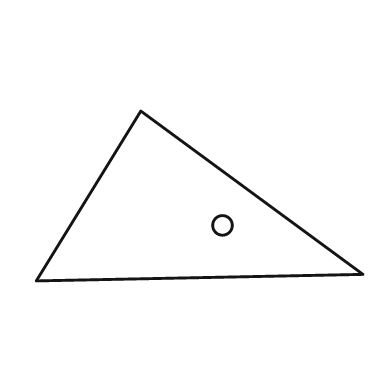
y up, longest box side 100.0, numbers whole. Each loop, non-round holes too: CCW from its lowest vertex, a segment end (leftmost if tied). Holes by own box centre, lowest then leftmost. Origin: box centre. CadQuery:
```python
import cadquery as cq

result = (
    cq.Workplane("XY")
    .moveTo(-50.0, -26.0)
    .lineTo(50.0, -24.0)
    .lineTo(-18.0, 26.0)
    .close()
    .moveTo(7.0, -9.0)
    .circle(3.0)
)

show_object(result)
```